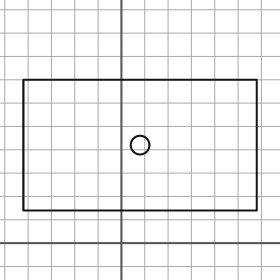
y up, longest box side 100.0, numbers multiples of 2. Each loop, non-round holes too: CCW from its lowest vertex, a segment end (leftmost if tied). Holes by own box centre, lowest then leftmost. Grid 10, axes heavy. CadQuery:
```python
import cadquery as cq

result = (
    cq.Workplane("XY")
    .moveTo(-42.0, 14.0)
    .lineTo(58.0, 14.0)
    .lineTo(58.0, 70.0)
    .lineTo(-42.0, 70.0)
    .close()
    .moveTo(8.0, 42.0)
    .circle(4.0)
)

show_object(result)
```